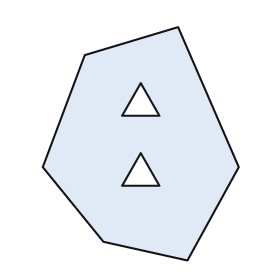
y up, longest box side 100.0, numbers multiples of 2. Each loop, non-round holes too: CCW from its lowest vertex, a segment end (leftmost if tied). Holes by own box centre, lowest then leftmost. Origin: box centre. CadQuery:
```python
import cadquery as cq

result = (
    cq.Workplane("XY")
    .moveTo(20.0, -50.0)
    .lineTo(42.0, -10.0)
    .lineTo(16.0, 50.0)
    .lineTo(-24.0, 38.0)
    .lineTo(-42.0, -10.0)
    .lineTo(-16.0, -42.0)
    .close()
    .moveTo(-8.0, -18.0)
    .lineTo(8.0, -18.0)
    .lineTo(0.0, -4.0)
    .close()
    .moveTo(-8.0, 12.0)
    .lineTo(8.0, 12.0)
    .lineTo(0.0, 26.0)
    .close()
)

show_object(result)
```